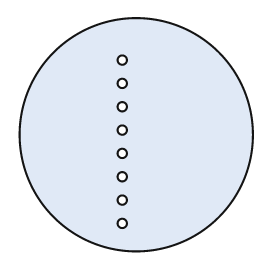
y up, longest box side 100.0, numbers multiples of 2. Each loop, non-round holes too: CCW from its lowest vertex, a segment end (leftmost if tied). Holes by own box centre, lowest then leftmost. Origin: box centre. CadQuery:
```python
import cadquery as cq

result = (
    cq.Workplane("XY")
    .moveTo(0.0, 0.0)
    .circle(50.0)
    .moveTo(-6.0, -38.0)
    .circle(2.0)
    .moveTo(-6.0, -28.0)
    .circle(2.0)
    .moveTo(-6.0, -18.0)
    .circle(2.0)
    .moveTo(-6.0, -8.0)
    .circle(2.0)
    .moveTo(-6.0, 2.0)
    .circle(2.0)
    .moveTo(-6.0, 12.0)
    .circle(2.0)
    .moveTo(-6.0, 22.0)
    .circle(2.0)
    .moveTo(-6.0, 32.0)
    .circle(2.0)
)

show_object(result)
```